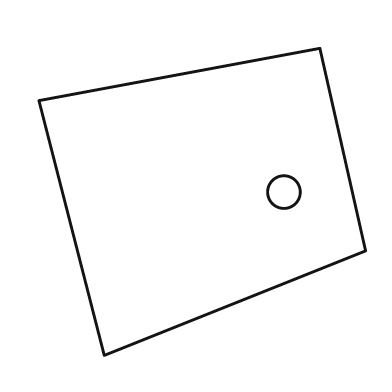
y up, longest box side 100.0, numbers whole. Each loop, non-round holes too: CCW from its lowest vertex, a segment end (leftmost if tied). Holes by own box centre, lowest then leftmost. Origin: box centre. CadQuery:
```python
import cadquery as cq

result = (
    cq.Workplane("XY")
    .moveTo(-30.0, -47.0)
    .lineTo(50.0, -15.0)
    .lineTo(36.0, 47.0)
    .lineTo(-50.0, 31.0)
    .close()
    .moveTo(25.0, 3.0)
    .circle(5.0)
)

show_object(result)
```